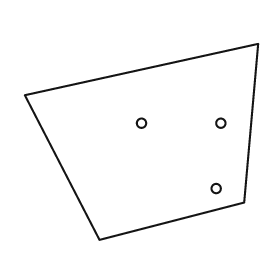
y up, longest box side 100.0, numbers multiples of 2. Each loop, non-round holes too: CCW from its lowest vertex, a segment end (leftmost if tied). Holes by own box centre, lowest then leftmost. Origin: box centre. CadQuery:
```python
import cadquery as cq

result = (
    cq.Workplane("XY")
    .moveTo(-18.0, -42.0)
    .lineTo(44.0, -26.0)
    .lineTo(50.0, 42.0)
    .lineTo(-50.0, 20.0)
    .close()
    .moveTo(32.0, -20.0)
    .circle(2.0)
    .moveTo(0.0, 8.0)
    .circle(2.0)
    .moveTo(34.0, 8.0)
    .circle(2.0)
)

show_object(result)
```